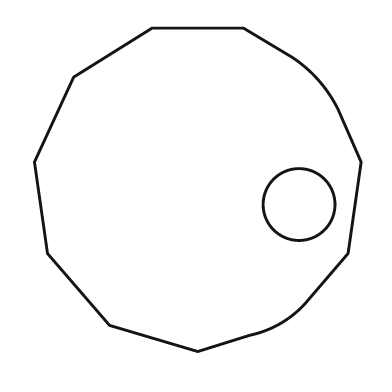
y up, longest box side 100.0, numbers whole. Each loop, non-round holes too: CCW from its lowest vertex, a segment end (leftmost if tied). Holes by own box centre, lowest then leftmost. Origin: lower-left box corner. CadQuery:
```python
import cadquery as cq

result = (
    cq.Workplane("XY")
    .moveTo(50.0, 0.0)
    .lineTo(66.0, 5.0)
    .threePointArc((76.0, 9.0), (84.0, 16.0))
    .lineTo(96.0, 30.0)
    .lineTo(100.0, 58.0)
    .lineTo(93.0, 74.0)
    .threePointArc((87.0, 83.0), (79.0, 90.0))
    .lineTo(64.0, 99.0)
    .lineTo(36.0, 99.0)
    .lineTo(12.0, 84.0)
    .lineTo(0.0, 58.0)
    .lineTo(4.0, 30.0)
    .lineTo(23.0, 8.0)
    .close()
    .moveTo(81.0, 45.0)
    .circle(11.0)
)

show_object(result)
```